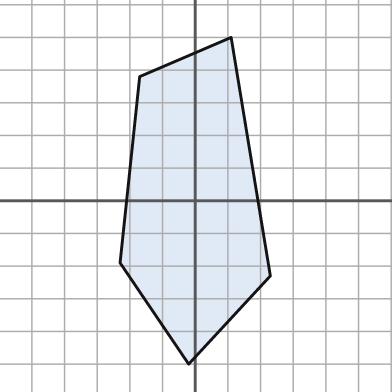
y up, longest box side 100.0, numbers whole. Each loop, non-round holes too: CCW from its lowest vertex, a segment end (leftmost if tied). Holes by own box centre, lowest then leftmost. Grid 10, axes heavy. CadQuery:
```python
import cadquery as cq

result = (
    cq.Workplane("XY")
    .moveTo(-2.0, -50.0)
    .lineTo(23.0, -23.0)
    .lineTo(11.0, 50.0)
    .lineTo(-17.0, 38.0)
    .lineTo(-23.0, -19.0)
    .close()
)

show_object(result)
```